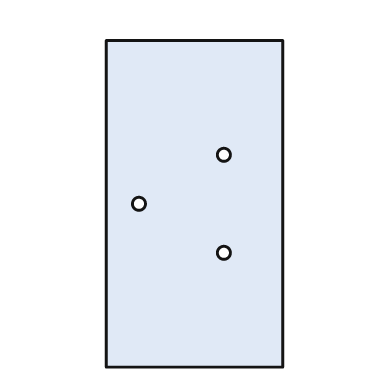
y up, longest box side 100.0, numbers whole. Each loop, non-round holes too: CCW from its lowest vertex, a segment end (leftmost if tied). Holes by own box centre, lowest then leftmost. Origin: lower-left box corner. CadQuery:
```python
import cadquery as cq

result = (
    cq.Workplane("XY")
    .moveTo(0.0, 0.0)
    .lineTo(54.0, 0.0)
    .lineTo(54.0, 100.0)
    .lineTo(0.0, 100.0)
    .close()
    .moveTo(36.0, 35.0)
    .circle(2.0)
    .moveTo(10.0, 50.0)
    .circle(2.0)
    .moveTo(36.0, 65.0)
    .circle(2.0)
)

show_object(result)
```